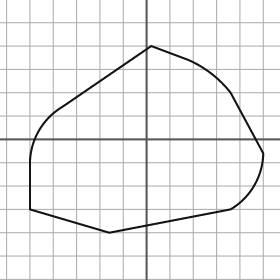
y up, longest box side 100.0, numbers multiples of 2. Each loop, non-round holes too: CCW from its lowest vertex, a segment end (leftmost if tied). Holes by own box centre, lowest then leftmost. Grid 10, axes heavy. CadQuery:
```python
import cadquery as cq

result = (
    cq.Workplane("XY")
    .moveTo(-16.0, -40.0)
    .lineTo(36.0, -30.0)
    .threePointArc((46.0, -20.0), (50.0, -6.0))
    .lineTo(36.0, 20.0)
    .threePointArc((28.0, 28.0), (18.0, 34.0))
    .lineTo(2.0, 40.0)
    .lineTo(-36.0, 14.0)
    .threePointArc((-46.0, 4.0), (-50.0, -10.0))
    .lineTo(-50.0, -30.0)
    .close()
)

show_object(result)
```